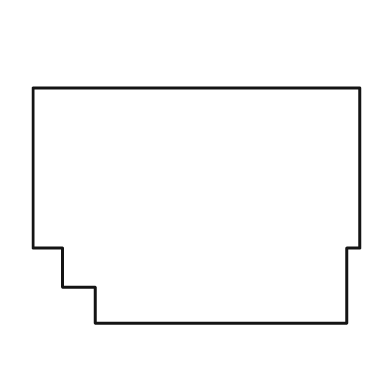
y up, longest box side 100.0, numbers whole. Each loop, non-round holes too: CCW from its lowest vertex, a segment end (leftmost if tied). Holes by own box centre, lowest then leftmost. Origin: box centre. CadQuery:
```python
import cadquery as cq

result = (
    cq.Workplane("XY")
    .moveTo(-31.0, -36.0)
    .lineTo(46.0, -36.0)
    .lineTo(46.0, -13.0)
    .lineTo(50.0, -13.0)
    .lineTo(50.0, 36.0)
    .lineTo(-50.0, 36.0)
    .lineTo(-50.0, -13.0)
    .lineTo(-41.0, -13.0)
    .lineTo(-41.0, -25.0)
    .lineTo(-31.0, -25.0)
    .close()
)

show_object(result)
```